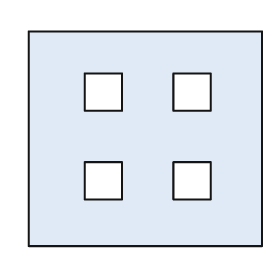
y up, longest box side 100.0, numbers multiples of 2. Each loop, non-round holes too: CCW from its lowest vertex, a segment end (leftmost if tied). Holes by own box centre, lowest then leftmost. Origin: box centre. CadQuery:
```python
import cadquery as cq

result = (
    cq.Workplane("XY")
    .moveTo(-50.0, -46.0)
    .lineTo(50.0, -46.0)
    .lineTo(50.0, 46.0)
    .lineTo(-50.0, 46.0)
    .close()
    .moveTo(-26.0, -26.0)
    .lineTo(-10.0, -26.0)
    .lineTo(-10.0, -10.0)
    .lineTo(-26.0, -10.0)
    .close()
    .moveTo(12.0, -26.0)
    .lineTo(28.0, -26.0)
    .lineTo(28.0, -10.0)
    .lineTo(12.0, -10.0)
    .close()
    .moveTo(-26.0, 12.0)
    .lineTo(-10.0, 12.0)
    .lineTo(-10.0, 28.0)
    .lineTo(-26.0, 28.0)
    .close()
    .moveTo(12.0, 12.0)
    .lineTo(28.0, 12.0)
    .lineTo(28.0, 28.0)
    .lineTo(12.0, 28.0)
    .close()
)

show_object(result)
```